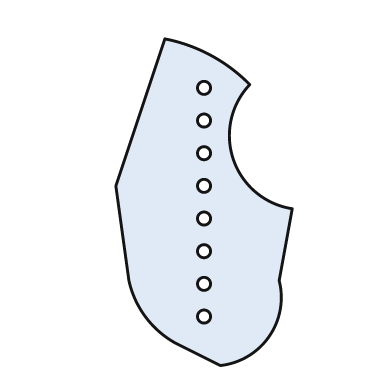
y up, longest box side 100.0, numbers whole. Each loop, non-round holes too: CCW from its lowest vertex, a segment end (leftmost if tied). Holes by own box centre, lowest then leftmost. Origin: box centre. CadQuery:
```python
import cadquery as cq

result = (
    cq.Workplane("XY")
    .moveTo(5.0, -50.0)
    .threePointArc((20.0, -41.0), (23.0, -24.0))
    .lineTo(27.0, -2.0)
    .threePointArc((9.0, 13.0), (14.0, 36.0))
    .threePointArc((2.0, 45.0), (-12.0, 50.0))
    .lineTo(-27.0, 5.0)
    .lineTo(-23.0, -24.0)
    .threePointArc((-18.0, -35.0), (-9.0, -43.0))
    .close()
    .moveTo(0.0, -35.0)
    .circle(2.0)
    .moveTo(0.0, -25.0)
    .circle(2.0)
    .moveTo(0.0, -15.0)
    .circle(2.0)
    .moveTo(0.0, -5.0)
    .circle(2.0)
    .moveTo(0.0, 5.0)
    .circle(2.0)
    .moveTo(0.0, 15.0)
    .circle(2.0)
    .moveTo(0.0, 25.0)
    .circle(2.0)
    .moveTo(0.0, 35.0)
    .circle(2.0)
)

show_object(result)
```